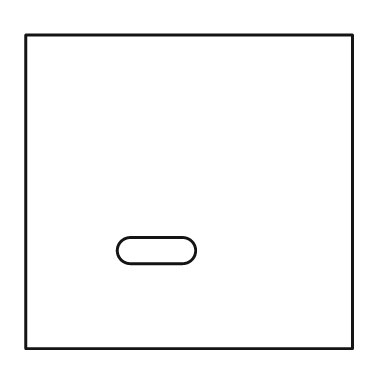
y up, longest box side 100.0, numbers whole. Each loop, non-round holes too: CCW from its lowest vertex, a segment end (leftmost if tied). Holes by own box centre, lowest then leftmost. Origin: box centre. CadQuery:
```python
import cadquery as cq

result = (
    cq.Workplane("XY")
    .moveTo(-50.0, -48.0)
    .lineTo(50.0, -48.0)
    .lineTo(50.0, 48.0)
    .lineTo(-50.0, 48.0)
    .close()
    .moveTo(-18.0, -22.0)
    .lineTo(-2.0, -22.0)
    .threePointArc((2.0, -18.0), (-2.0, -14.0))
    .lineTo(-18.0, -14.0)
    .threePointArc((-22.0, -18.0), (-18.0, -22.0))
    .close()
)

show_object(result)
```